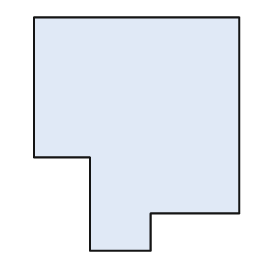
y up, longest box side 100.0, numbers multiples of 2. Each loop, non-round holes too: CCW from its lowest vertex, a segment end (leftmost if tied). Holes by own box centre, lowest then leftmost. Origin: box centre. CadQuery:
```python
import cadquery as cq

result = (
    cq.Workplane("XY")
    .moveTo(-20.0, -50.0)
    .lineTo(6.0, -50.0)
    .lineTo(6.0, -34.0)
    .lineTo(44.0, -34.0)
    .lineTo(44.0, 50.0)
    .lineTo(-44.0, 50.0)
    .lineTo(-44.0, -10.0)
    .lineTo(-20.0, -10.0)
    .close()
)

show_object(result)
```